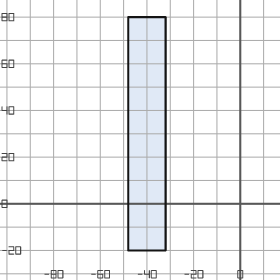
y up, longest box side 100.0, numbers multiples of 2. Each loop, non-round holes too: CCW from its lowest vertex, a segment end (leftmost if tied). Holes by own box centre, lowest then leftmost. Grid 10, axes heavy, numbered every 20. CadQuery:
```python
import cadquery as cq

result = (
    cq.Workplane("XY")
    .moveTo(-48.0, -20.0)
    .lineTo(-32.0, -20.0)
    .lineTo(-32.0, 80.0)
    .lineTo(-48.0, 80.0)
    .close()
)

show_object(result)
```